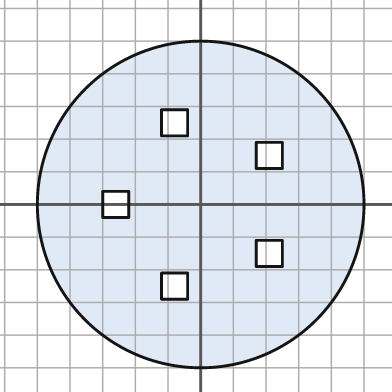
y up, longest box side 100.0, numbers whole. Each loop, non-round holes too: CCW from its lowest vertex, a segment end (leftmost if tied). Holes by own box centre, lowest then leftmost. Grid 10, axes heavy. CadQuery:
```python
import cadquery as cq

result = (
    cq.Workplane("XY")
    .moveTo(0.0, 0.0)
    .circle(50.0)
    .moveTo(-12.0, -29.0)
    .lineTo(-4.0, -29.0)
    .lineTo(-4.0, -21.0)
    .lineTo(-12.0, -21.0)
    .close()
    .moveTo(17.0, -19.0)
    .lineTo(25.0, -19.0)
    .lineTo(25.0, -11.0)
    .lineTo(17.0, -11.0)
    .close()
    .moveTo(-30.0, -4.0)
    .lineTo(-22.0, -4.0)
    .lineTo(-22.0, 4.0)
    .lineTo(-30.0, 4.0)
    .close()
    .moveTo(17.0, 11.0)
    .lineTo(25.0, 11.0)
    .lineTo(25.0, 19.0)
    .lineTo(17.0, 19.0)
    .close()
    .moveTo(-12.0, 21.0)
    .lineTo(-4.0, 21.0)
    .lineTo(-4.0, 29.0)
    .lineTo(-12.0, 29.0)
    .close()
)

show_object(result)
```